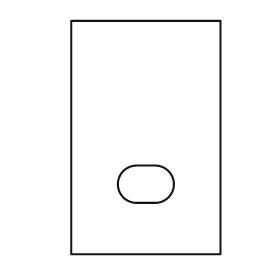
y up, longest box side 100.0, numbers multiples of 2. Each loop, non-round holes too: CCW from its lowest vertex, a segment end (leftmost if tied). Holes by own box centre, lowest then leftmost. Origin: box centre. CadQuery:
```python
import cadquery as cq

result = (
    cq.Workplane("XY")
    .moveTo(-32.0, -50.0)
    .lineTo(32.0, -50.0)
    .lineTo(32.0, 50.0)
    .lineTo(-32.0, 50.0)
    .close()
    .moveTo(-4.0, -28.0)
    .lineTo(4.0, -28.0)
    .threePointArc((12.0, -20.0), (4.0, -12.0))
    .lineTo(-4.0, -12.0)
    .threePointArc((-12.0, -20.0), (-4.0, -28.0))
    .close()
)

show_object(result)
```